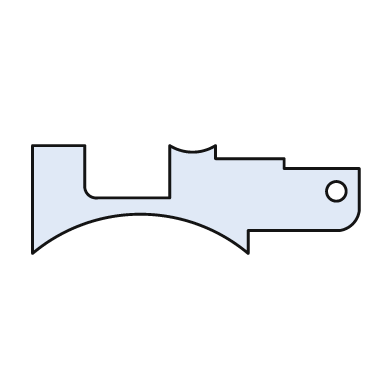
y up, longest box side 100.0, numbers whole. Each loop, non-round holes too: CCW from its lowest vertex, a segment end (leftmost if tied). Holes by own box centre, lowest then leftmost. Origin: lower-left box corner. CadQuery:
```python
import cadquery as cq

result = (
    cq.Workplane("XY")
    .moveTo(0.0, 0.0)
    .threePointArc((33.0, 12.0), (66.0, 0.0))
    .lineTo(66.0, 7.0)
    .lineTo(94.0, 7.0)
    .threePointArc((98.0, 9.0), (100.0, 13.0))
    .lineTo(100.0, 26.0)
    .lineTo(77.0, 26.0)
    .lineTo(77.0, 29.0)
    .lineTo(56.0, 29.0)
    .lineTo(56.0, 33.0)
    .threePointArc((49.0, 31.0), (42.0, 33.0))
    .lineTo(42.0, 17.0)
    .lineTo(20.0, 17.0)
    .threePointArc((17.0, 18.0), (16.0, 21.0))
    .lineTo(16.0, 33.0)
    .lineTo(0.0, 33.0)
    .close()
    .moveTo(93.0, 19.0)
    .circle(3.0)
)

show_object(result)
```